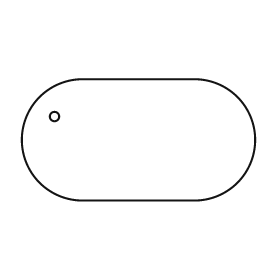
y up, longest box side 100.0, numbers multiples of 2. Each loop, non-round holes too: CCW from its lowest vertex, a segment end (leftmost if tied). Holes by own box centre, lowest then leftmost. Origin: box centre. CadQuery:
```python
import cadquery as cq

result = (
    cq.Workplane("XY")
    .moveTo(-24.0, -26.0)
    .lineTo(24.0, -26.0)
    .threePointArc((50.0, 0.0), (24.0, 26.0))
    .lineTo(-24.0, 26.0)
    .threePointArc((-50.0, 0.0), (-24.0, -26.0))
    .close()
    .moveTo(-36.0, 10.0)
    .circle(2.0)
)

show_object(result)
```